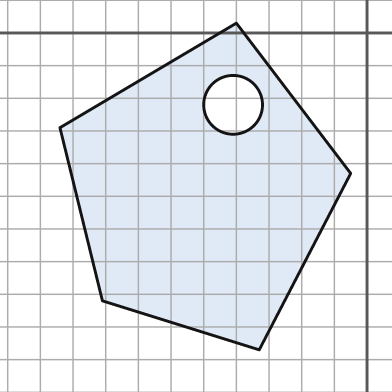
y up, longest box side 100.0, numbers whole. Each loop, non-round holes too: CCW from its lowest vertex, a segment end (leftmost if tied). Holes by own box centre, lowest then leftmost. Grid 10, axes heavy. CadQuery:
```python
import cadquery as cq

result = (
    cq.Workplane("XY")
    .moveTo(-33.0, -97.0)
    .lineTo(-5.0, -43.0)
    .lineTo(-40.0, 3.0)
    .lineTo(-94.0, -29.0)
    .lineTo(-81.0, -82.0)
    .close()
    .moveTo(-41.0, -22.0)
    .circle(9.0)
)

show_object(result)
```